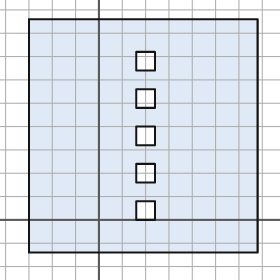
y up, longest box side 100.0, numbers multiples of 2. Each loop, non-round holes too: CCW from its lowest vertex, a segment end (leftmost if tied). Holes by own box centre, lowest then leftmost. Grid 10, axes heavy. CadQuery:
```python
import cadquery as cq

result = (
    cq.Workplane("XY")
    .moveTo(-30.0, -14.0)
    .lineTo(68.0, -14.0)
    .lineTo(68.0, 86.0)
    .lineTo(-30.0, 86.0)
    .close()
    .moveTo(16.0, 0.0)
    .lineTo(24.0, 0.0)
    .lineTo(24.0, 8.0)
    .lineTo(16.0, 8.0)
    .close()
    .moveTo(16.0, 16.0)
    .lineTo(24.0, 16.0)
    .lineTo(24.0, 24.0)
    .lineTo(16.0, 24.0)
    .close()
    .moveTo(16.0, 32.0)
    .lineTo(24.0, 32.0)
    .lineTo(24.0, 40.0)
    .lineTo(16.0, 40.0)
    .close()
    .moveTo(16.0, 48.0)
    .lineTo(24.0, 48.0)
    .lineTo(24.0, 56.0)
    .lineTo(16.0, 56.0)
    .close()
    .moveTo(16.0, 64.0)
    .lineTo(24.0, 64.0)
    .lineTo(24.0, 72.0)
    .lineTo(16.0, 72.0)
    .close()
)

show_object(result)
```